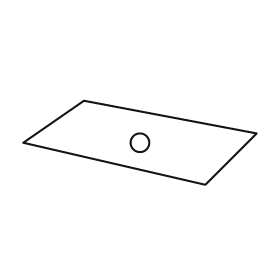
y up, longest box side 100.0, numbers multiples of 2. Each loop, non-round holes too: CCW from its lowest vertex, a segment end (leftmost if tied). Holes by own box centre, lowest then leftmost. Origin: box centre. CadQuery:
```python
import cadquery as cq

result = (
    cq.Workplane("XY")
    .moveTo(28.0, -18.0)
    .lineTo(50.0, 4.0)
    .lineTo(-24.0, 18.0)
    .lineTo(-50.0, 0.0)
    .close()
    .moveTo(0.0, 0.0)
    .circle(4.0)
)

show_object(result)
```